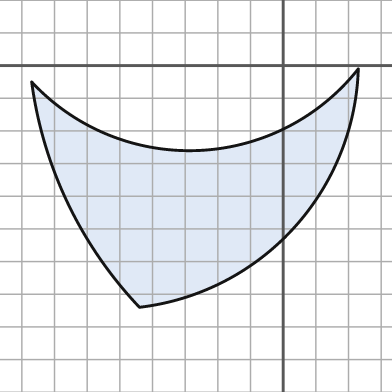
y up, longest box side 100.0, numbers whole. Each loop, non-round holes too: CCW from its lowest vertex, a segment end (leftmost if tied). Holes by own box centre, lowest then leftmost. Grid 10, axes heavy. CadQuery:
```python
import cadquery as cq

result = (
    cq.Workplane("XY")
    .moveTo(-44.0, -74.0)
    .threePointArc((3.0, -50.0), (23.0, -1.0))
    .threePointArc((-26.0, -26.0), (-77.0, -5.0))
    .threePointArc((-66.0, -42.0), (-44.0, -74.0))
    .close()
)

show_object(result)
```